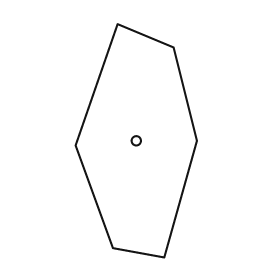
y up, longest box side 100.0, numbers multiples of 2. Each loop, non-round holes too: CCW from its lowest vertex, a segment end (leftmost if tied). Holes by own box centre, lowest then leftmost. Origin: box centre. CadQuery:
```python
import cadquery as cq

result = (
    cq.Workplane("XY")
    .moveTo(12.0, -50.0)
    .lineTo(26.0, 0.0)
    .lineTo(16.0, 40.0)
    .lineTo(-8.0, 50.0)
    .lineTo(-26.0, -2.0)
    .lineTo(-10.0, -46.0)
    .close()
    .moveTo(0.0, 0.0)
    .circle(2.0)
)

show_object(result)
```